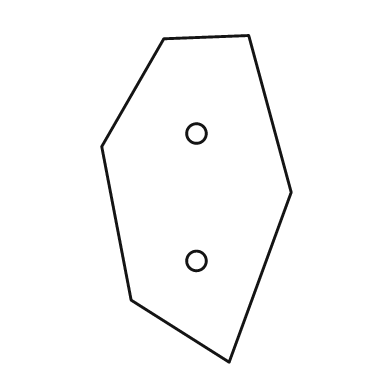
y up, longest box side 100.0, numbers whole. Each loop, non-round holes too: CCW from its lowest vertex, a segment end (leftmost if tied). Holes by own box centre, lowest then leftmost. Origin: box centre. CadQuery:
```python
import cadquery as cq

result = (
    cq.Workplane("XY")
    .moveTo(10.0, -50.0)
    .lineTo(29.0, 2.0)
    .lineTo(16.0, 50.0)
    .lineTo(-10.0, 49.0)
    .lineTo(-29.0, 16.0)
    .lineTo(-20.0, -31.0)
    .close()
    .moveTo(0.0, -19.0)
    .circle(3.0)
    .moveTo(0.0, 20.0)
    .circle(3.0)
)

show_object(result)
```